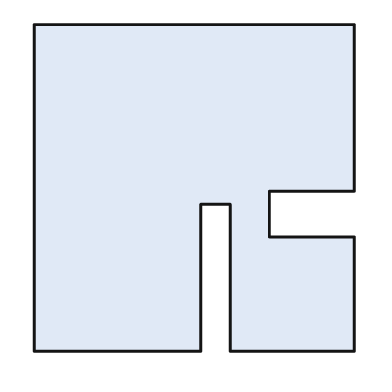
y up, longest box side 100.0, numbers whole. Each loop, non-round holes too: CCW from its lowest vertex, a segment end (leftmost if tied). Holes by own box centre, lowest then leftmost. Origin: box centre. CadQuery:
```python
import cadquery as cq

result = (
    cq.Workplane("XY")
    .moveTo(-49.0, -50.0)
    .lineTo(2.0, -50.0)
    .lineTo(2.0, -5.0)
    .lineTo(11.0, -5.0)
    .lineTo(11.0, -50.0)
    .lineTo(49.0, -50.0)
    .lineTo(49.0, -15.0)
    .lineTo(23.0, -15.0)
    .lineTo(23.0, -1.0)
    .lineTo(49.0, -1.0)
    .lineTo(49.0, 50.0)
    .lineTo(-49.0, 50.0)
    .close()
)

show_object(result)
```